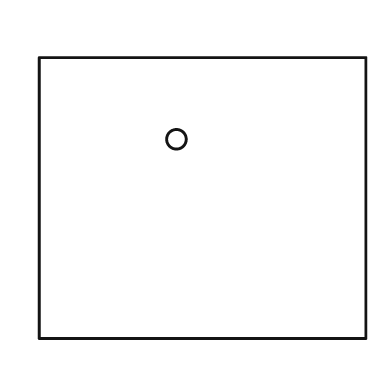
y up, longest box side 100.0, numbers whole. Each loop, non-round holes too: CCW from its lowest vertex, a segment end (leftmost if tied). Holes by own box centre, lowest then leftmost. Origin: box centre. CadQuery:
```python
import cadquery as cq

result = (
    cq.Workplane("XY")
    .moveTo(-50.0, -43.0)
    .lineTo(50.0, -43.0)
    .lineTo(50.0, 43.0)
    .lineTo(-50.0, 43.0)
    .close()
    .moveTo(-8.0, 18.0)
    .circle(3.0)
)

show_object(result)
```